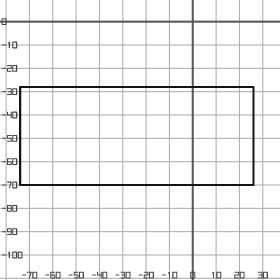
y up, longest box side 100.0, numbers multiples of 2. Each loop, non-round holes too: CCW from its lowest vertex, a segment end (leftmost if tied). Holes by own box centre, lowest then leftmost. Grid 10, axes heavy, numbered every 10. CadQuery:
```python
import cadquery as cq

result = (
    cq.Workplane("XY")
    .moveTo(-74.0, -70.0)
    .lineTo(26.0, -70.0)
    .lineTo(26.0, -28.0)
    .lineTo(-74.0, -28.0)
    .close()
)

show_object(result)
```